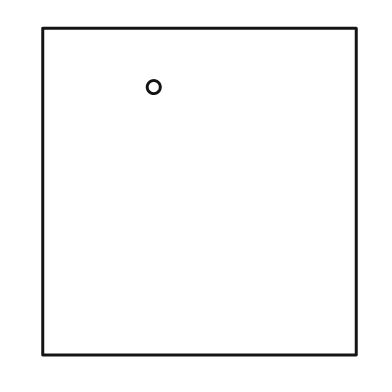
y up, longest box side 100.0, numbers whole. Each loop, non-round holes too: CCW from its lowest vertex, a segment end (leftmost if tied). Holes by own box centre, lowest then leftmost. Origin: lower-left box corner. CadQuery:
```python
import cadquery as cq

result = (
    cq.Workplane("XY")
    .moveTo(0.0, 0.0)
    .lineTo(96.0, 0.0)
    .lineTo(96.0, 100.0)
    .lineTo(0.0, 100.0)
    .close()
    .moveTo(34.0, 82.0)
    .circle(2.0)
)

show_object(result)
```